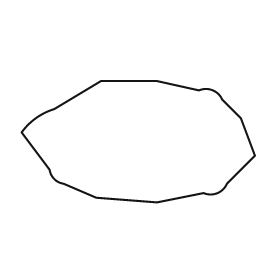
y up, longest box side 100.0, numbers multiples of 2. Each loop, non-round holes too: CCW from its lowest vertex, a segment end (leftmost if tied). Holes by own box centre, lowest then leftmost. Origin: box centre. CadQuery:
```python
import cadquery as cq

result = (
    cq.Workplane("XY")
    .moveTo(8.0, -26.0)
    .lineTo(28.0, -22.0)
    .threePointArc((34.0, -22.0), (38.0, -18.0))
    .lineTo(50.0, -6.0)
    .lineTo(44.0, 10.0)
    .lineTo(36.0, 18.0)
    .threePointArc((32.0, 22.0), (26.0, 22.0))
    .lineTo(8.0, 26.0)
    .lineTo(-16.0, 26.0)
    .lineTo(-36.0, 14.0)
    .threePointArc((-44.0, 10.0), (-50.0, 4.0))
    .lineTo(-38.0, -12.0)
    .threePointArc((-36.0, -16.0), (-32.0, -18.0))
    .lineTo(-18.0, -24.0)
    .close()
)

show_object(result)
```